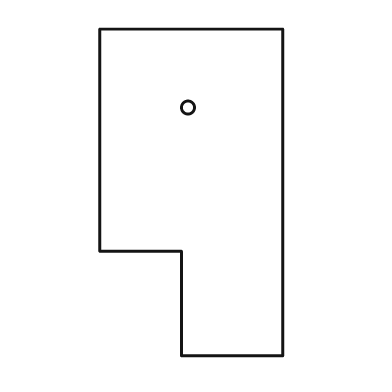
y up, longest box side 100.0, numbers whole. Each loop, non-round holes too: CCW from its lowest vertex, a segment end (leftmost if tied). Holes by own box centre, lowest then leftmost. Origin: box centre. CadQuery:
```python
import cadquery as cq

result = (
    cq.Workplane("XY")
    .moveTo(-3.0, -50.0)
    .lineTo(28.0, -50.0)
    .lineTo(28.0, 50.0)
    .lineTo(-28.0, 50.0)
    .lineTo(-28.0, -18.0)
    .lineTo(-3.0, -18.0)
    .close()
    .moveTo(-1.0, 26.0)
    .circle(2.0)
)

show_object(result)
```